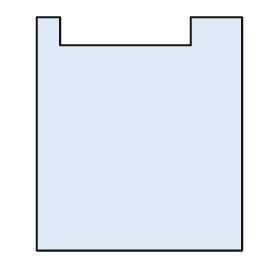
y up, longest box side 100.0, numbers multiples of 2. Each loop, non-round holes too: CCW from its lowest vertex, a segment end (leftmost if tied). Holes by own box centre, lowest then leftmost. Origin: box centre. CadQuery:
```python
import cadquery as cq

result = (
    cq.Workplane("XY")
    .moveTo(-44.0, -50.0)
    .lineTo(44.0, -50.0)
    .lineTo(44.0, 50.0)
    .lineTo(22.0, 50.0)
    .lineTo(22.0, 38.0)
    .lineTo(-34.0, 38.0)
    .lineTo(-34.0, 50.0)
    .lineTo(-44.0, 50.0)
    .close()
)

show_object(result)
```